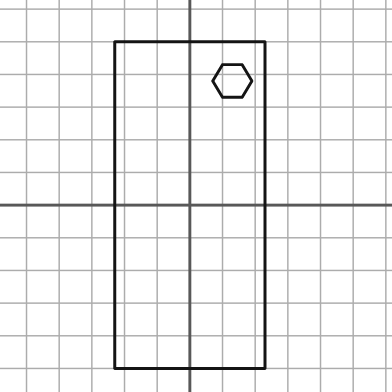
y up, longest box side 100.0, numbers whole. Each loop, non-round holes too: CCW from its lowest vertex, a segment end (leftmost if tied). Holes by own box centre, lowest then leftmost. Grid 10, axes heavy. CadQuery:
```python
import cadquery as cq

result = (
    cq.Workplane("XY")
    .moveTo(-23.0, -50.0)
    .lineTo(23.0, -50.0)
    .lineTo(23.0, 50.0)
    .lineTo(-23.0, 50.0)
    .close()
    .moveTo(10.0, 33.0)
    .lineTo(16.0, 33.0)
    .lineTo(19.0, 38.0)
    .lineTo(16.0, 43.0)
    .lineTo(10.0, 43.0)
    .lineTo(7.0, 38.0)
    .close()
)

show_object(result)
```